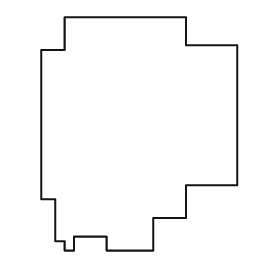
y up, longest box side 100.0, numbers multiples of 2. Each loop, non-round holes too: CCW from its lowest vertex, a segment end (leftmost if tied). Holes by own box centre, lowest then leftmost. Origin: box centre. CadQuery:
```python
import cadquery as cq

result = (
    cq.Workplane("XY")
    .moveTo(-32.0, -50.0)
    .lineTo(-28.0, -50.0)
    .lineTo(-28.0, -44.0)
    .lineTo(-14.0, -44.0)
    .lineTo(-14.0, -50.0)
    .lineTo(6.0, -50.0)
    .lineTo(6.0, -36.0)
    .lineTo(20.0, -36.0)
    .lineTo(20.0, -22.0)
    .lineTo(42.0, -22.0)
    .lineTo(42.0, 38.0)
    .lineTo(20.0, 38.0)
    .lineTo(20.0, 50.0)
    .lineTo(-32.0, 50.0)
    .lineTo(-32.0, 36.0)
    .lineTo(-42.0, 36.0)
    .lineTo(-42.0, -28.0)
    .lineTo(-36.0, -28.0)
    .lineTo(-36.0, -46.0)
    .lineTo(-32.0, -46.0)
    .close()
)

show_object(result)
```